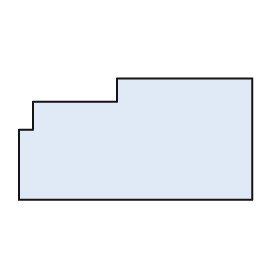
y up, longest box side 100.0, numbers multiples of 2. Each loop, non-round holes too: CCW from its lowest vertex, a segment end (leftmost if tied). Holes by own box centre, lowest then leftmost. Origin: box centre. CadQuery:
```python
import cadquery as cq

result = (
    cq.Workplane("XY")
    .moveTo(-50.0, -26.0)
    .lineTo(50.0, -26.0)
    .lineTo(50.0, 26.0)
    .lineTo(-8.0, 26.0)
    .lineTo(-8.0, 16.0)
    .lineTo(-44.0, 16.0)
    .lineTo(-44.0, 4.0)
    .lineTo(-50.0, 4.0)
    .close()
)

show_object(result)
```